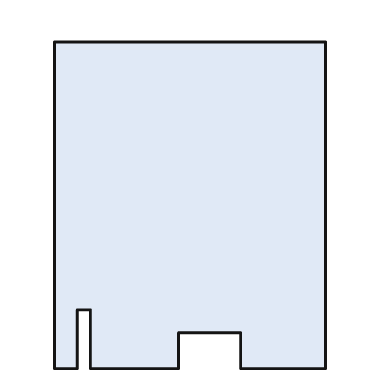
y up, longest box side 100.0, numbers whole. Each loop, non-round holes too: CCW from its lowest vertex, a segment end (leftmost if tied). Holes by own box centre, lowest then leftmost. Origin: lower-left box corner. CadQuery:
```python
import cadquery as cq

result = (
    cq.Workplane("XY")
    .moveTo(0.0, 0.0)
    .lineTo(7.0, 0.0)
    .lineTo(7.0, 18.0)
    .lineTo(11.0, 18.0)
    .lineTo(11.0, 0.0)
    .lineTo(38.0, 0.0)
    .lineTo(38.0, 11.0)
    .lineTo(57.0, 11.0)
    .lineTo(57.0, 0.0)
    .lineTo(83.0, 0.0)
    .lineTo(83.0, 100.0)
    .lineTo(0.0, 100.0)
    .close()
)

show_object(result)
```